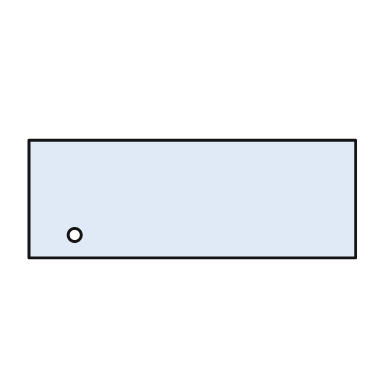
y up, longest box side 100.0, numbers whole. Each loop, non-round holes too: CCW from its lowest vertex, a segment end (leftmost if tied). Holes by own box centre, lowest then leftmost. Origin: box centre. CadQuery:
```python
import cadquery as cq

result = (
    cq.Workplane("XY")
    .moveTo(-50.0, -18.0)
    .lineTo(50.0, -18.0)
    .lineTo(50.0, 18.0)
    .lineTo(-50.0, 18.0)
    .close()
    .moveTo(-36.0, -11.0)
    .circle(2.0)
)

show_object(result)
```